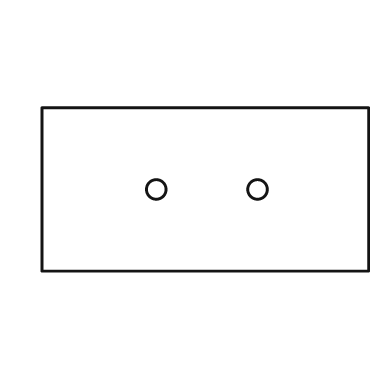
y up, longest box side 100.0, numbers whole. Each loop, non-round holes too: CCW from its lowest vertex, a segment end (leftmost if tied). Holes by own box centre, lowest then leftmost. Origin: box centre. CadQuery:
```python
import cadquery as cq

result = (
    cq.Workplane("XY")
    .moveTo(-50.0, -25.0)
    .lineTo(50.0, -25.0)
    .lineTo(50.0, 25.0)
    .lineTo(-50.0, 25.0)
    .close()
    .moveTo(-15.0, 0.0)
    .circle(3.0)
    .moveTo(16.0, 0.0)
    .circle(3.0)
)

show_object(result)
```